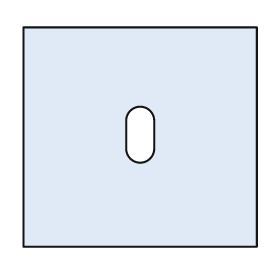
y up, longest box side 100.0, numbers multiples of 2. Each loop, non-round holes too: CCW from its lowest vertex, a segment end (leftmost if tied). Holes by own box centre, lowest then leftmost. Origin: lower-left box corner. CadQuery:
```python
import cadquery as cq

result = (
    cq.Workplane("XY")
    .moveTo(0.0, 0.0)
    .lineTo(100.0, 0.0)
    .lineTo(100.0, 94.0)
    .lineTo(0.0, 94.0)
    .close()
    .moveTo(44.0, 42.0)
    .threePointArc((50.0, 36.0), (56.0, 42.0))
    .lineTo(56.0, 54.0)
    .threePointArc((50.0, 60.0), (44.0, 54.0))
    .close()
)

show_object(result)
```